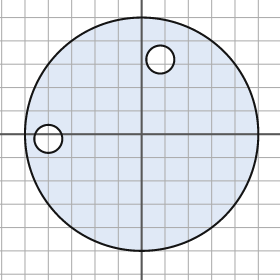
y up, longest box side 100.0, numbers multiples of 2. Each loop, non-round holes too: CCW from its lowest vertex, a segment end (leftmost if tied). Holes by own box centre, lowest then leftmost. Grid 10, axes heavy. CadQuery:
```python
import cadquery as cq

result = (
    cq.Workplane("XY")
    .moveTo(0.0, 0.0)
    .circle(50.0)
    .moveTo(-40.0, -2.0)
    .circle(6.0)
    .moveTo(8.0, 32.0)
    .circle(6.0)
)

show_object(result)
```